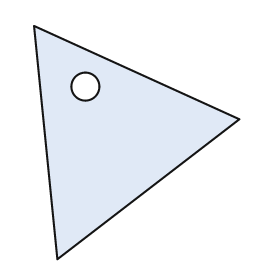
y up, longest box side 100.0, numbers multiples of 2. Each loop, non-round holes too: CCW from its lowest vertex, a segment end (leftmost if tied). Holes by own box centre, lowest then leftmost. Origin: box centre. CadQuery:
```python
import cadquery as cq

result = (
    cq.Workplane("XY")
    .moveTo(-34.0, -50.0)
    .lineTo(44.0, 10.0)
    .lineTo(-44.0, 50.0)
    .close()
    .moveTo(-22.0, 24.0)
    .circle(6.0)
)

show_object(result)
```